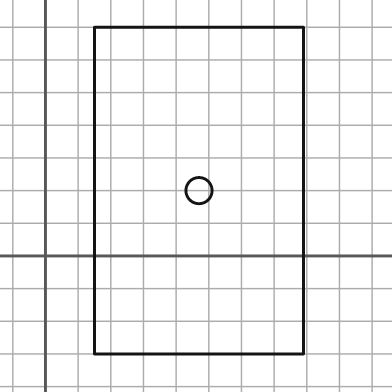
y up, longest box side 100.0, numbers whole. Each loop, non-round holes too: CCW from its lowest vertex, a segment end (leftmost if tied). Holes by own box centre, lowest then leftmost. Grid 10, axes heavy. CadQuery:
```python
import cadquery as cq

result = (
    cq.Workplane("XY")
    .moveTo(15.0, -30.0)
    .lineTo(79.0, -30.0)
    .lineTo(79.0, 70.0)
    .lineTo(15.0, 70.0)
    .close()
    .moveTo(47.0, 20.0)
    .circle(4.0)
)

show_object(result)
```